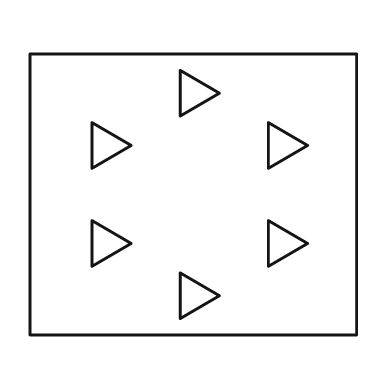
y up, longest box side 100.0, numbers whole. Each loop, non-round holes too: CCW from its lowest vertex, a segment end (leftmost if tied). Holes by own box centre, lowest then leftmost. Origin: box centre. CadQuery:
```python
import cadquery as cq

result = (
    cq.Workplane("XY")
    .moveTo(-50.0, -43.0)
    .lineTo(50.0, -43.0)
    .lineTo(50.0, 43.0)
    .lineTo(-50.0, 43.0)
    .close()
    .moveTo(-4.0, -38.0)
    .lineTo(8.0, -31.0)
    .lineTo(-4.0, -24.0)
    .close()
    .moveTo(-31.0, -22.0)
    .lineTo(-19.0, -15.0)
    .lineTo(-31.0, -8.0)
    .close()
    .moveTo(23.0, -22.0)
    .lineTo(35.0, -15.0)
    .lineTo(23.0, -8.0)
    .close()
    .moveTo(-31.0, 8.0)
    .lineTo(-19.0, 15.0)
    .lineTo(-31.0, 22.0)
    .close()
    .moveTo(23.0, 8.0)
    .lineTo(35.0, 15.0)
    .lineTo(23.0, 22.0)
    .close()
    .moveTo(-4.0, 24.0)
    .lineTo(8.0, 31.0)
    .lineTo(-4.0, 38.0)
    .close()
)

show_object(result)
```